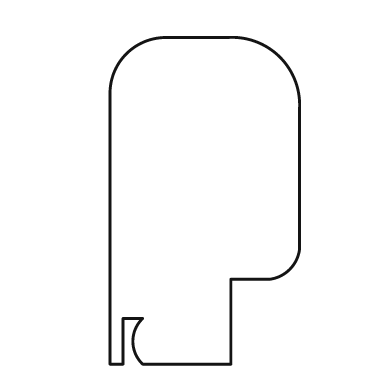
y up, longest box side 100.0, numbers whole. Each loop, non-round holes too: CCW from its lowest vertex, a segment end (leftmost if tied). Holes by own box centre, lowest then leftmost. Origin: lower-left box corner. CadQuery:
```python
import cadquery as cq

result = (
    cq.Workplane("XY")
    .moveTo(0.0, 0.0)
    .lineTo(4.0, 0.0)
    .lineTo(4.0, 14.0)
    .lineTo(10.0, 14.0)
    .threePointArc((7.0, 7.0), (10.0, 0.0))
    .lineTo(37.0, 0.0)
    .lineTo(37.0, 26.0)
    .lineTo(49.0, 26.0)
    .threePointArc((55.0, 29.0), (58.0, 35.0))
    .lineTo(58.0, 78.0)
    .threePointArc((52.0, 94.0), (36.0, 100.0))
    .lineTo(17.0, 100.0)
    .threePointArc((5.0, 95.0), (0.0, 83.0))
    .close()
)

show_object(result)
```